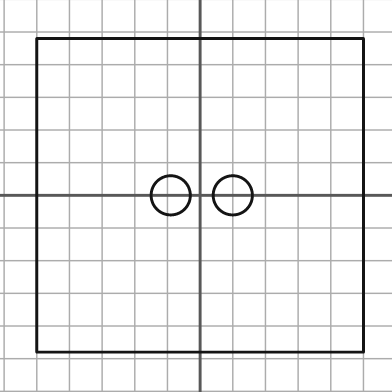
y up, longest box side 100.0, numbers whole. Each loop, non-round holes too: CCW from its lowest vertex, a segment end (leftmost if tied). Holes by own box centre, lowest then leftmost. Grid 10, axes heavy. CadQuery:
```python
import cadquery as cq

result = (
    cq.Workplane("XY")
    .moveTo(-50.0, -48.0)
    .lineTo(50.0, -48.0)
    .lineTo(50.0, 48.0)
    .lineTo(-50.0, 48.0)
    .close()
    .moveTo(-9.0, 0.0)
    .circle(6.0)
    .moveTo(10.0, 0.0)
    .circle(6.0)
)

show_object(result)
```